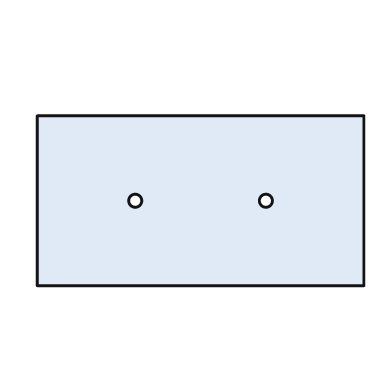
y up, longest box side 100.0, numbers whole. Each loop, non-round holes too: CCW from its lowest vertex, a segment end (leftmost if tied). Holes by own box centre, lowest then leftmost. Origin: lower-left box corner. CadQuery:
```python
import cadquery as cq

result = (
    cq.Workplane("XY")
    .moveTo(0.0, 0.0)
    .lineTo(100.0, 0.0)
    .lineTo(100.0, 52.0)
    .lineTo(0.0, 52.0)
    .close()
    .moveTo(30.0, 26.0)
    .circle(2.0)
    .moveTo(70.0, 26.0)
    .circle(2.0)
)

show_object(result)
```